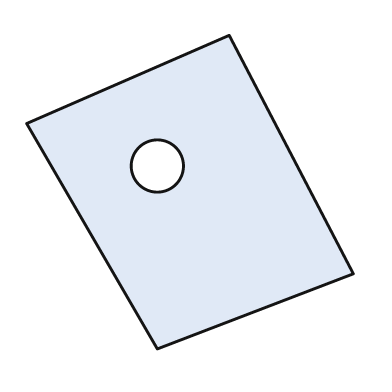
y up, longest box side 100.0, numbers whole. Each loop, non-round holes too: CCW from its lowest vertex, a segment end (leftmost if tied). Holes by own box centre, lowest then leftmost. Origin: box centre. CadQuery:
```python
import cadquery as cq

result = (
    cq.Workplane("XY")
    .moveTo(-10.0, -48.0)
    .lineTo(50.0, -25.0)
    .lineTo(12.0, 48.0)
    .lineTo(-50.0, 21.0)
    .close()
    .moveTo(-10.0, 8.0)
    .circle(8.0)
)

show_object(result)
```